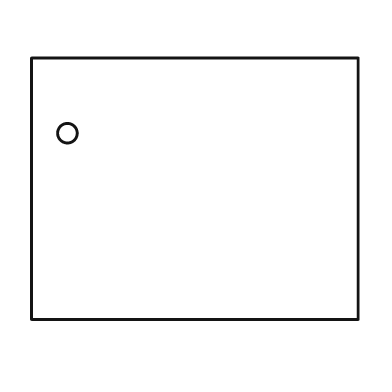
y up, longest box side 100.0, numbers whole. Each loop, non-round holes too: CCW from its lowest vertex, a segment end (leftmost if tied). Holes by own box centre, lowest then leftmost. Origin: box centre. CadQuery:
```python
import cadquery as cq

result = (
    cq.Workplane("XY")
    .moveTo(-50.0, -40.0)
    .lineTo(50.0, -40.0)
    .lineTo(50.0, 40.0)
    .lineTo(-50.0, 40.0)
    .close()
    .moveTo(-39.0, 17.0)
    .circle(3.0)
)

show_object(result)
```